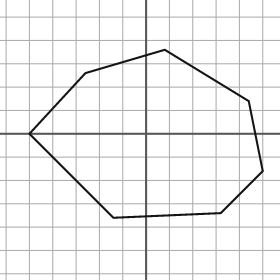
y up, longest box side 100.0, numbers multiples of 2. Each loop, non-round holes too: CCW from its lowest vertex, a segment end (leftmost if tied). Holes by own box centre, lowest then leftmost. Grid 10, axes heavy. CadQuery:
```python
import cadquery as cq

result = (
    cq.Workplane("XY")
    .moveTo(-14.0, -36.0)
    .lineTo(32.0, -34.0)
    .lineTo(50.0, -16.0)
    .lineTo(44.0, 14.0)
    .lineTo(8.0, 36.0)
    .lineTo(-26.0, 26.0)
    .lineTo(-50.0, 0.0)
    .close()
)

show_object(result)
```